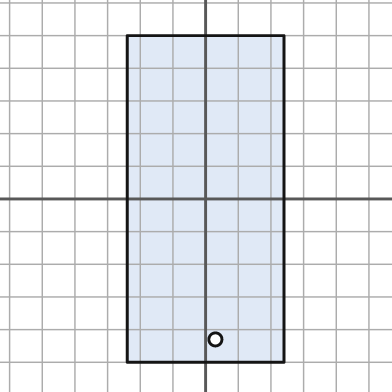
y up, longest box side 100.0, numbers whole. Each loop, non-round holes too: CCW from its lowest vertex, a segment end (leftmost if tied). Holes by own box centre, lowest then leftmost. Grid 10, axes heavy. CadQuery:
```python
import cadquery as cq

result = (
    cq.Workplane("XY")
    .moveTo(-24.0, -50.0)
    .lineTo(24.0, -50.0)
    .lineTo(24.0, 50.0)
    .lineTo(-24.0, 50.0)
    .close()
    .moveTo(3.0, -43.0)
    .circle(2.0)
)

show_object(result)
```